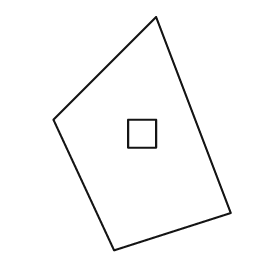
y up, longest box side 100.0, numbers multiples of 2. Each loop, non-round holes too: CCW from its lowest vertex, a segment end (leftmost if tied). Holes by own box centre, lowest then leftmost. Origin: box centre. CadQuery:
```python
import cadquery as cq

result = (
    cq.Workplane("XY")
    .moveTo(-12.0, -50.0)
    .lineTo(38.0, -34.0)
    .lineTo(6.0, 50.0)
    .lineTo(-38.0, 6.0)
    .close()
    .moveTo(-6.0, -6.0)
    .lineTo(6.0, -6.0)
    .lineTo(6.0, 6.0)
    .lineTo(-6.0, 6.0)
    .close()
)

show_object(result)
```